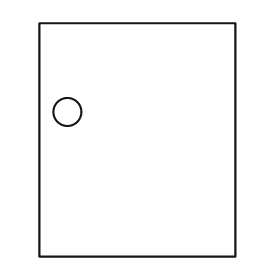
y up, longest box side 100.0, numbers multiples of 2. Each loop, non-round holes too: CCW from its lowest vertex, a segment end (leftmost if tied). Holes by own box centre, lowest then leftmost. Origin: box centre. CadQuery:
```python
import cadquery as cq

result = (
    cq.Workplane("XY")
    .moveTo(-42.0, -50.0)
    .lineTo(42.0, -50.0)
    .lineTo(42.0, 50.0)
    .lineTo(-42.0, 50.0)
    .close()
    .moveTo(-30.0, 12.0)
    .circle(6.0)
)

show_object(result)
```